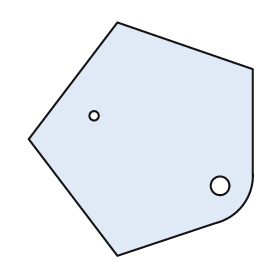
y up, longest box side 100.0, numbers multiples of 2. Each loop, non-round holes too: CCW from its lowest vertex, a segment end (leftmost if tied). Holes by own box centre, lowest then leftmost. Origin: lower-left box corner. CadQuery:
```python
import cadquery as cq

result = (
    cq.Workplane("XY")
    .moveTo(38.0, 0.0)
    .lineTo(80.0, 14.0)
    .threePointArc((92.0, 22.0), (96.0, 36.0))
    .lineTo(96.0, 80.0)
    .lineTo(38.0, 100.0)
    .lineTo(0.0, 50.0)
    .close()
    .moveTo(82.0, 30.0)
    .circle(4.0)
    .moveTo(28.0, 60.0)
    .circle(2.0)
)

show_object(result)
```